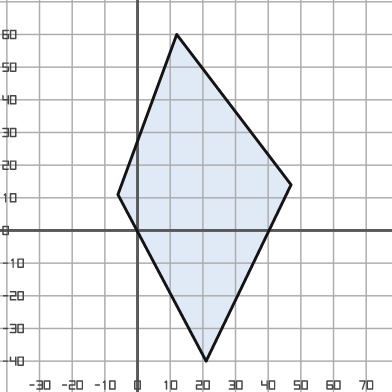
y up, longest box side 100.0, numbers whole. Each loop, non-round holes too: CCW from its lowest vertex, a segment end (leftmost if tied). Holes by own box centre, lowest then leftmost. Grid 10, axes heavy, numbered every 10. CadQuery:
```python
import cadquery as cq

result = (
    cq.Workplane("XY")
    .moveTo(21.0, -40.0)
    .lineTo(47.0, 14.0)
    .lineTo(12.0, 60.0)
    .lineTo(-6.0, 11.0)
    .close()
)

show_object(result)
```